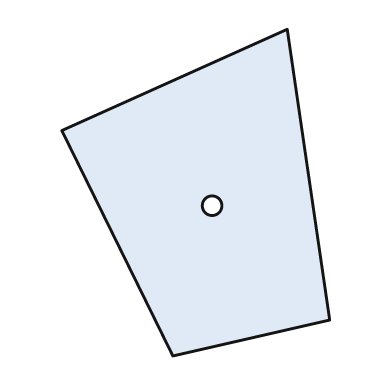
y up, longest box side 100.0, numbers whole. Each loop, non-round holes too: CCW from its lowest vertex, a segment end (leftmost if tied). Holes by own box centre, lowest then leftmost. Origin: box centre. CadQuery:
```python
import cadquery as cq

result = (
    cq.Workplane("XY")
    .moveTo(-7.0, -50.0)
    .lineTo(41.0, -39.0)
    .lineTo(28.0, 50.0)
    .lineTo(-41.0, 19.0)
    .close()
    .moveTo(5.0, -4.0)
    .circle(3.0)
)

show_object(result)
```